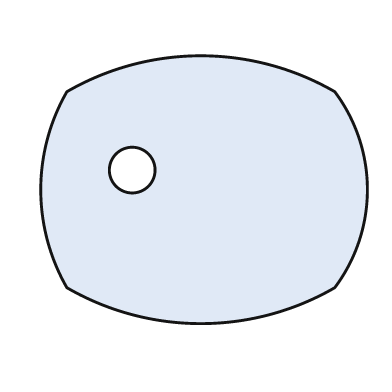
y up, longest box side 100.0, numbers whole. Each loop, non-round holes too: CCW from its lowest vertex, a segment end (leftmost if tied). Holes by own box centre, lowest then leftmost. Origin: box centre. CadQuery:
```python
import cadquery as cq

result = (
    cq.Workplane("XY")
    .moveTo(-42.0, -30.0)
    .threePointArc((-1.0, -41.0), (40.0, -30.0))
    .threePointArc((50.0, 0.0), (40.0, 30.0))
    .threePointArc((-1.0, 41.0), (-42.0, 30.0))
    .threePointArc((-50.0, 0.0), (-42.0, -30.0))
    .close()
    .moveTo(-22.0, 6.0)
    .circle(7.0)
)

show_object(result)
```